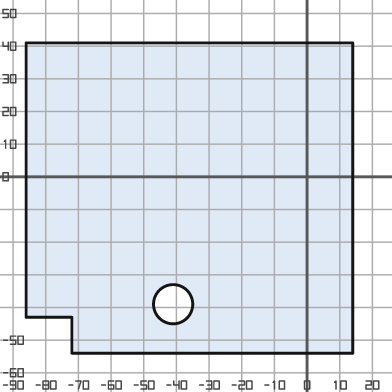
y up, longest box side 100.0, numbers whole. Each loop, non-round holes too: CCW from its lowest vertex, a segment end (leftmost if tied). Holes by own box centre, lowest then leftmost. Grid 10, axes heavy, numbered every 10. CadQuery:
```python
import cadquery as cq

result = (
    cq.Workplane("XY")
    .moveTo(-72.0, -54.0)
    .lineTo(14.0, -54.0)
    .lineTo(14.0, 41.0)
    .lineTo(-86.0, 41.0)
    .lineTo(-86.0, -43.0)
    .lineTo(-72.0, -43.0)
    .close()
    .moveTo(-41.0, -39.0)
    .circle(6.0)
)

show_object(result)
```